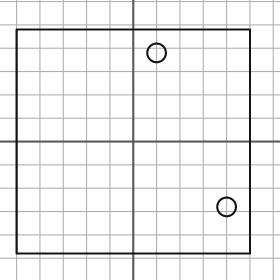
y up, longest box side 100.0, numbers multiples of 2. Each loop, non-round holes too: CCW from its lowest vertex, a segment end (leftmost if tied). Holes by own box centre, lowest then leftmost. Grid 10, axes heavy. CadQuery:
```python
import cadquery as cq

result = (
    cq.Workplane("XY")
    .moveTo(-50.0, -48.0)
    .lineTo(50.0, -48.0)
    .lineTo(50.0, 48.0)
    .lineTo(-50.0, 48.0)
    .close()
    .moveTo(40.0, -28.0)
    .circle(4.0)
    .moveTo(10.0, 38.0)
    .circle(4.0)
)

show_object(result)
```